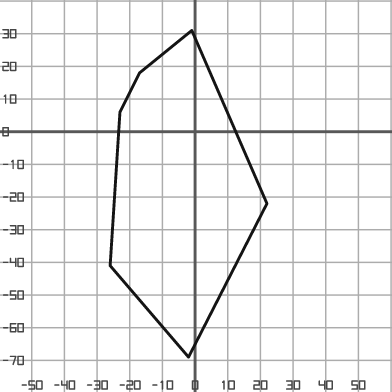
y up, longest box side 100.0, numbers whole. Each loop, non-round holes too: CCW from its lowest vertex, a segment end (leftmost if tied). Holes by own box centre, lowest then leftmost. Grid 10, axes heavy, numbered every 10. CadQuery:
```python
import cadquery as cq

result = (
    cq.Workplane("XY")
    .moveTo(-2.0, -69.0)
    .lineTo(22.0, -22.0)
    .lineTo(-1.0, 31.0)
    .lineTo(-17.0, 18.0)
    .lineTo(-23.0, 6.0)
    .lineTo(-26.0, -41.0)
    .close()
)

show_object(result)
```